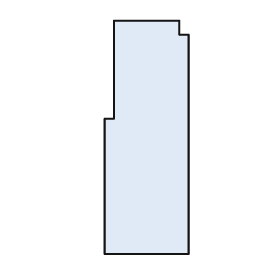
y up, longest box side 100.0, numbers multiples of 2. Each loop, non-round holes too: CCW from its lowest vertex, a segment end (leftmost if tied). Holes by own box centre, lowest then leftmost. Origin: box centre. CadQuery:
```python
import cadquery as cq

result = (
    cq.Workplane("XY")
    .moveTo(-18.0, -50.0)
    .lineTo(18.0, -50.0)
    .lineTo(18.0, 44.0)
    .lineTo(14.0, 44.0)
    .lineTo(14.0, 50.0)
    .lineTo(-14.0, 50.0)
    .lineTo(-14.0, 8.0)
    .lineTo(-18.0, 8.0)
    .close()
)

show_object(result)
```